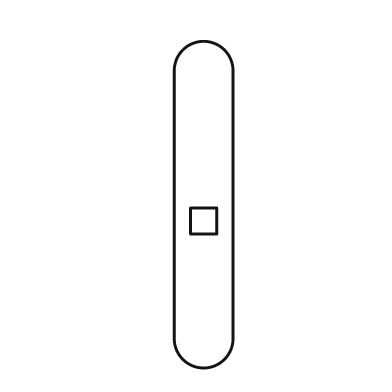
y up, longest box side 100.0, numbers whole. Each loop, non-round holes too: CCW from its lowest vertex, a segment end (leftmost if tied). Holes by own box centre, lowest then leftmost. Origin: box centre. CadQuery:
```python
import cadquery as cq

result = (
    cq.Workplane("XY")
    .moveTo(-9.0, -41.0)
    .threePointArc((0.0, -50.0), (9.0, -41.0))
    .lineTo(9.0, 41.0)
    .threePointArc((0.0, 50.0), (-9.0, 41.0))
    .close()
    .moveTo(-4.0, -9.0)
    .lineTo(4.0, -9.0)
    .lineTo(4.0, -1.0)
    .lineTo(-4.0, -1.0)
    .close()
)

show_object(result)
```